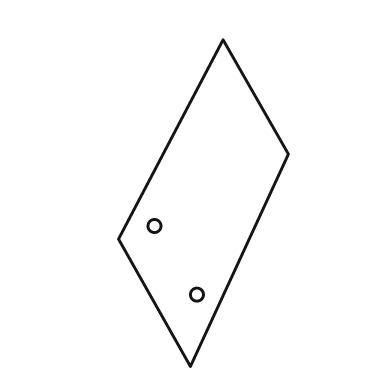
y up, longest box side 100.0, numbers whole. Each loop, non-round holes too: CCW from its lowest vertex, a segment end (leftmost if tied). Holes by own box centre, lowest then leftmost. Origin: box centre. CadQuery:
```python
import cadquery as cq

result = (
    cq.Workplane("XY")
    .moveTo(-4.0, -50.0)
    .lineTo(26.0, 15.0)
    .lineTo(6.0, 50.0)
    .lineTo(-26.0, -11.0)
    .close()
    .moveTo(-2.0, -28.0)
    .circle(2.0)
    .moveTo(-15.0, -7.0)
    .circle(2.0)
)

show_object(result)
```